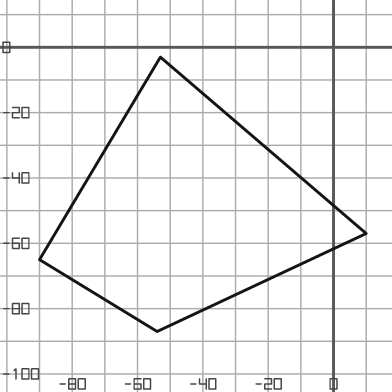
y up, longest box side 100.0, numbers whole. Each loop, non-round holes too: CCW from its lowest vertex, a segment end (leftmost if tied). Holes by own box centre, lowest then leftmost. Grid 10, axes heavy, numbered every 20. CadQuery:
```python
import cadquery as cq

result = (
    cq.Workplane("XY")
    .moveTo(-54.0, -87.0)
    .lineTo(10.0, -57.0)
    .lineTo(-53.0, -3.0)
    .lineTo(-90.0, -65.0)
    .close()
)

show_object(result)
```